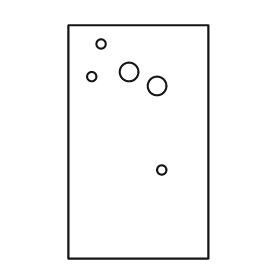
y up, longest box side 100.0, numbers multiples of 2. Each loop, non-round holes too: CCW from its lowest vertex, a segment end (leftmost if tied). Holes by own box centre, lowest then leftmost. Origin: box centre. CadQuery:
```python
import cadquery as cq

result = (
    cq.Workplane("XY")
    .moveTo(-30.0, -50.0)
    .lineTo(30.0, -50.0)
    .lineTo(30.0, 50.0)
    .lineTo(-30.0, 50.0)
    .close()
    .moveTo(10.0, -12.0)
    .circle(2.0)
    .moveTo(8.0, 24.0)
    .circle(4.0)
    .moveTo(-20.0, 28.0)
    .circle(2.0)
    .moveTo(-4.0, 30.0)
    .circle(4.0)
    .moveTo(-16.0, 42.0)
    .circle(2.0)
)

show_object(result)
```